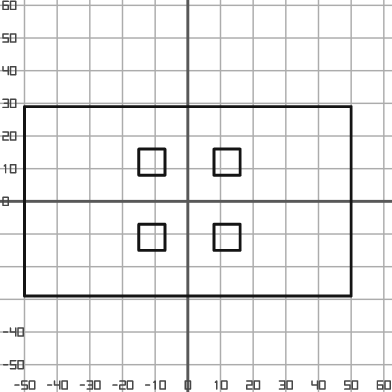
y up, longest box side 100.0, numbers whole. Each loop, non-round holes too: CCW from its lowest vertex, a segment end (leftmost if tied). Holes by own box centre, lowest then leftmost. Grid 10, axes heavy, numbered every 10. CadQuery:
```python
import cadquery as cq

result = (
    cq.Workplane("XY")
    .moveTo(-50.0, -29.0)
    .lineTo(50.0, -29.0)
    .lineTo(50.0, 29.0)
    .lineTo(-50.0, 29.0)
    .close()
    .moveTo(-15.0, -15.0)
    .lineTo(-7.0, -15.0)
    .lineTo(-7.0, -7.0)
    .lineTo(-15.0, -7.0)
    .close()
    .moveTo(8.0, -15.0)
    .lineTo(16.0, -15.0)
    .lineTo(16.0, -7.0)
    .lineTo(8.0, -7.0)
    .close()
    .moveTo(-15.0, 8.0)
    .lineTo(-7.0, 8.0)
    .lineTo(-7.0, 16.0)
    .lineTo(-15.0, 16.0)
    .close()
    .moveTo(8.0, 8.0)
    .lineTo(16.0, 8.0)
    .lineTo(16.0, 16.0)
    .lineTo(8.0, 16.0)
    .close()
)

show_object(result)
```